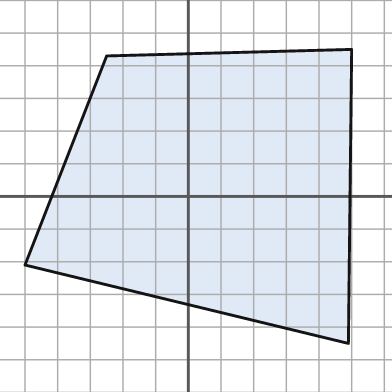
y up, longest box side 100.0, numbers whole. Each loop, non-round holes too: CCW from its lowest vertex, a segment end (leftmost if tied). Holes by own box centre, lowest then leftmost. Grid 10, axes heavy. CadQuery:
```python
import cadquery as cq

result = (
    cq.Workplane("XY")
    .moveTo(49.0, -45.0)
    .lineTo(50.0, 45.0)
    .lineTo(-25.0, 43.0)
    .lineTo(-50.0, -21.0)
    .close()
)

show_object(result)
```